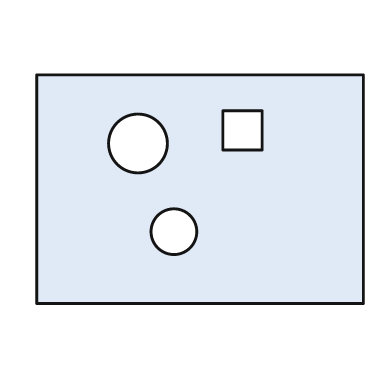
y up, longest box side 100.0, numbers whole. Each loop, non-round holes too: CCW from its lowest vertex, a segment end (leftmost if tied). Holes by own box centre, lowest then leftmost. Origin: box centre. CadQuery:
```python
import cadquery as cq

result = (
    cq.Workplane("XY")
    .moveTo(-50.0, -35.0)
    .lineTo(50.0, -35.0)
    .lineTo(50.0, 35.0)
    .lineTo(-50.0, 35.0)
    .close()
    .moveTo(-8.0, -13.0)
    .circle(7.0)
    .moveTo(-19.0, 14.0)
    .circle(9.0)
    .moveTo(7.0, 12.0)
    .lineTo(19.0, 12.0)
    .lineTo(19.0, 24.0)
    .lineTo(7.0, 24.0)
    .close()
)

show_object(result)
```